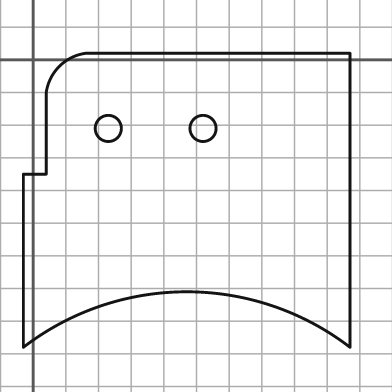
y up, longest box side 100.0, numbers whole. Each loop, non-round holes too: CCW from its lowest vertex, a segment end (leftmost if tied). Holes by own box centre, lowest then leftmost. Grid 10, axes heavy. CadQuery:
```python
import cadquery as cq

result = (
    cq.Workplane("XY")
    .moveTo(-3.0, -88.0)
    .threePointArc((47.0, -71.0), (97.0, -88.0))
    .lineTo(97.0, 2.0)
    .lineTo(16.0, 2.0)
    .threePointArc((8.0, -2.0), (4.0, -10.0))
    .lineTo(4.0, -35.0)
    .lineTo(-3.0, -35.0)
    .close()
    .moveTo(23.0, -21.0)
    .circle(4.0)
    .moveTo(52.0, -21.0)
    .circle(4.0)
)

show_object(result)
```